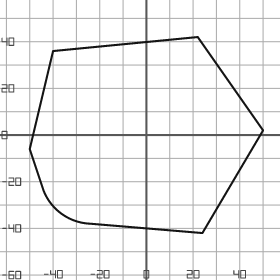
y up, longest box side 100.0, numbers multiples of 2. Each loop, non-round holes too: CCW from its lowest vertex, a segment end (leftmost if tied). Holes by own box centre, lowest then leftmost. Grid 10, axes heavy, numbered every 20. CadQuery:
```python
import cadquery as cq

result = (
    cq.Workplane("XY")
    .moveTo(24.0, -42.0)
    .lineTo(50.0, 2.0)
    .lineTo(22.0, 42.0)
    .lineTo(-40.0, 36.0)
    .lineTo(-50.0, -6.0)
    .lineTo(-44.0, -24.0)
    .threePointArc((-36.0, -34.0), (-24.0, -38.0))
    .close()
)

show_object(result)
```